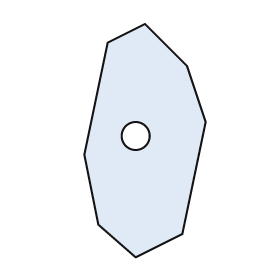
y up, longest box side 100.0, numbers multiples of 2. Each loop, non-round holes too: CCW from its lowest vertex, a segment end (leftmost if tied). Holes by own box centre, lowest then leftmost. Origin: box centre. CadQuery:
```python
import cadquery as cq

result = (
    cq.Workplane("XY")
    .moveTo(-4.0, -50.0)
    .lineTo(16.0, -40.0)
    .lineTo(26.0, 8.0)
    .lineTo(18.0, 32.0)
    .lineTo(0.0, 50.0)
    .lineTo(-16.0, 42.0)
    .lineTo(-26.0, -6.0)
    .lineTo(-20.0, -36.0)
    .close()
    .moveTo(-4.0, 2.0)
    .circle(6.0)
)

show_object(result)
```